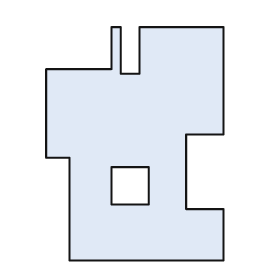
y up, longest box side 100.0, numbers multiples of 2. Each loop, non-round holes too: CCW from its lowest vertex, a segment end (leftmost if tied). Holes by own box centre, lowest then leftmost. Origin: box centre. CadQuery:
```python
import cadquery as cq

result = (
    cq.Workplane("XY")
    .moveTo(-28.0, -50.0)
    .lineTo(38.0, -50.0)
    .lineTo(38.0, -28.0)
    .lineTo(22.0, -28.0)
    .lineTo(22.0, 4.0)
    .lineTo(38.0, 4.0)
    .lineTo(38.0, 50.0)
    .lineTo(2.0, 50.0)
    .lineTo(2.0, 30.0)
    .lineTo(-6.0, 30.0)
    .lineTo(-6.0, 50.0)
    .lineTo(-10.0, 50.0)
    .lineTo(-10.0, 32.0)
    .lineTo(-38.0, 32.0)
    .lineTo(-38.0, -6.0)
    .lineTo(-28.0, -6.0)
    .close()
    .moveTo(-10.0, -26.0)
    .lineTo(6.0, -26.0)
    .lineTo(6.0, -10.0)
    .lineTo(-10.0, -10.0)
    .close()
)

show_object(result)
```